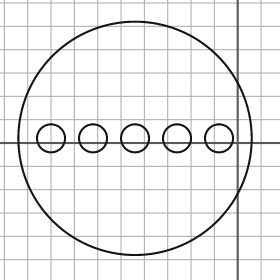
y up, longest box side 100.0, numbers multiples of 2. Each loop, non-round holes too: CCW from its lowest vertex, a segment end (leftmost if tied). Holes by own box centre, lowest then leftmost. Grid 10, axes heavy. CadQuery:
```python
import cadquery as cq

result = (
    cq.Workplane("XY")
    .moveTo(-44.0, 2.0)
    .circle(50.0)
    .moveTo(-80.0, 2.0)
    .circle(6.0)
    .moveTo(-62.0, 2.0)
    .circle(6.0)
    .moveTo(-44.0, 2.0)
    .circle(6.0)
    .moveTo(-26.0, 2.0)
    .circle(6.0)
    .moveTo(-8.0, 2.0)
    .circle(6.0)
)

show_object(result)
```